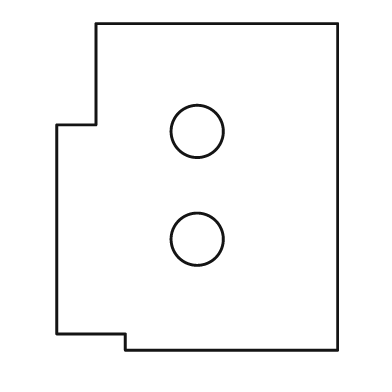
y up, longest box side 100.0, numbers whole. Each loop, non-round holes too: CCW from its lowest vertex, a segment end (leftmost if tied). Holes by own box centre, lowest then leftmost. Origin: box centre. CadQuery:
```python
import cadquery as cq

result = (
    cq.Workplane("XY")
    .moveTo(-22.0, -50.0)
    .lineTo(43.0, -50.0)
    .lineTo(43.0, 50.0)
    .lineTo(-31.0, 50.0)
    .lineTo(-31.0, 19.0)
    .lineTo(-43.0, 19.0)
    .lineTo(-43.0, -45.0)
    .lineTo(-22.0, -45.0)
    .close()
    .moveTo(0.0, -16.0)
    .circle(8.0)
    .moveTo(0.0, 17.0)
    .circle(8.0)
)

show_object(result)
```